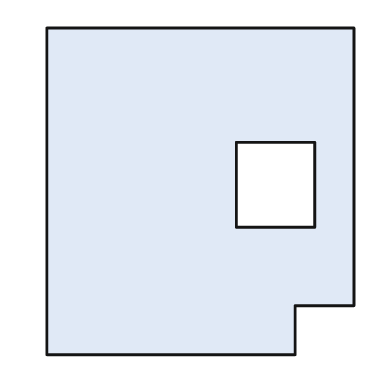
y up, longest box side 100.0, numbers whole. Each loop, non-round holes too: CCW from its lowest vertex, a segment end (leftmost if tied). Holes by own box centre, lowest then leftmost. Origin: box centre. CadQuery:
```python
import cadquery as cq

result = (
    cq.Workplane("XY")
    .moveTo(-47.0, -50.0)
    .lineTo(29.0, -50.0)
    .lineTo(29.0, -35.0)
    .lineTo(47.0, -35.0)
    .lineTo(47.0, 50.0)
    .lineTo(-47.0, 50.0)
    .close()
    .moveTo(11.0, -11.0)
    .lineTo(35.0, -11.0)
    .lineTo(35.0, 15.0)
    .lineTo(11.0, 15.0)
    .close()
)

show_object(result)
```